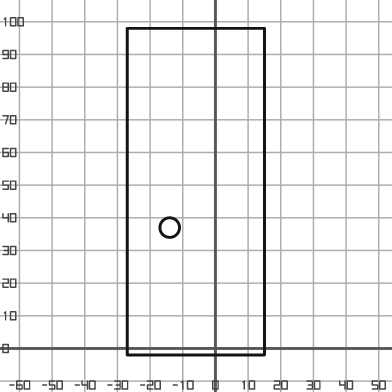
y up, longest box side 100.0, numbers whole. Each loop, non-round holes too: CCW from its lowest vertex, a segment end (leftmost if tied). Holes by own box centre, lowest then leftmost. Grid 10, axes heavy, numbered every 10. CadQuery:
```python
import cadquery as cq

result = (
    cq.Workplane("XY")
    .moveTo(-27.0, -2.0)
    .lineTo(15.0, -2.0)
    .lineTo(15.0, 98.0)
    .lineTo(-27.0, 98.0)
    .close()
    .moveTo(-14.0, 37.0)
    .circle(3.0)
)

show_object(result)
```